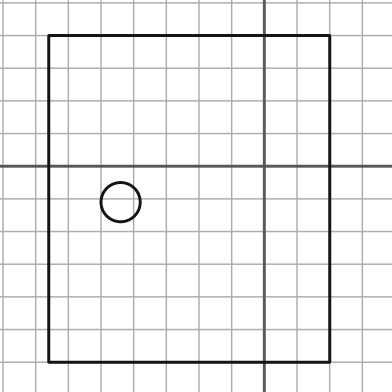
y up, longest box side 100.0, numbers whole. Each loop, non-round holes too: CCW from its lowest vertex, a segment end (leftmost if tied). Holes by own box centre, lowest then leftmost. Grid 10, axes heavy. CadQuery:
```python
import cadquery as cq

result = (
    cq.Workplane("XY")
    .moveTo(-66.0, -60.0)
    .lineTo(20.0, -60.0)
    .lineTo(20.0, 40.0)
    .lineTo(-66.0, 40.0)
    .close()
    .moveTo(-44.0, -11.0)
    .circle(6.0)
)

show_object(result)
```